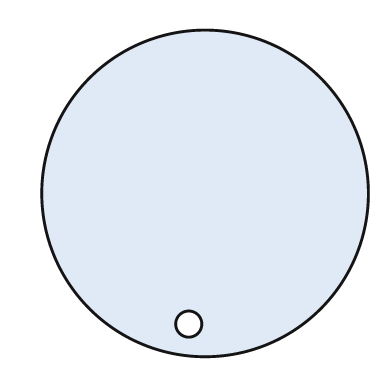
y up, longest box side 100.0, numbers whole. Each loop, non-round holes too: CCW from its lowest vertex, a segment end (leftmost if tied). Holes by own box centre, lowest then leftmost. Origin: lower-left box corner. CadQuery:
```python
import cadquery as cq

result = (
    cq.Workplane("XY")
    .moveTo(50.0, 50.0)
    .circle(50.0)
    .moveTo(45.0, 10.0)
    .circle(4.0)
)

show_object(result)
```